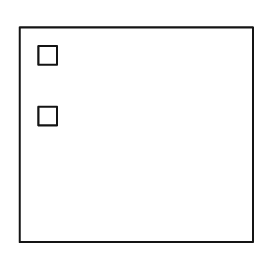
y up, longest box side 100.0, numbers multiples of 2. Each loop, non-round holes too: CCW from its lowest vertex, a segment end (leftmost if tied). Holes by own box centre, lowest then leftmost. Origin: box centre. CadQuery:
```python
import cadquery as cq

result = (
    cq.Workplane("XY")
    .moveTo(-50.0, -46.0)
    .lineTo(50.0, -46.0)
    .lineTo(50.0, 46.0)
    .lineTo(-50.0, 46.0)
    .close()
    .moveTo(-42.0, 4.0)
    .lineTo(-34.0, 4.0)
    .lineTo(-34.0, 12.0)
    .lineTo(-42.0, 12.0)
    .close()
    .moveTo(-42.0, 30.0)
    .lineTo(-34.0, 30.0)
    .lineTo(-34.0, 38.0)
    .lineTo(-42.0, 38.0)
    .close()
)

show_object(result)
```